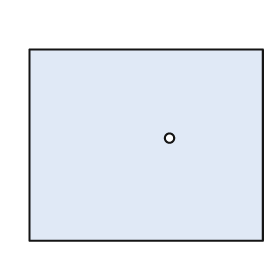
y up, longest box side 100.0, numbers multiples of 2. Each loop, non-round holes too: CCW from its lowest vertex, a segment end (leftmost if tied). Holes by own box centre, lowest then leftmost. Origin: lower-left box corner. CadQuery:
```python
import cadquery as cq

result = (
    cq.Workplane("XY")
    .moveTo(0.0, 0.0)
    .lineTo(100.0, 0.0)
    .lineTo(100.0, 82.0)
    .lineTo(0.0, 82.0)
    .close()
    .moveTo(60.0, 44.0)
    .circle(2.0)
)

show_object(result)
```